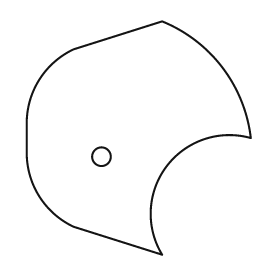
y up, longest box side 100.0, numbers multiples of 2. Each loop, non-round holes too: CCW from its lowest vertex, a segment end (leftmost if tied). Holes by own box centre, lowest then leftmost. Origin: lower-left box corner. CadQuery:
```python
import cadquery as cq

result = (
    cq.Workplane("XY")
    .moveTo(58.0, 0.0)
    .threePointArc((60.0, 38.0), (96.0, 50.0))
    .threePointArc((84.0, 80.0), (58.0, 100.0))
    .lineTo(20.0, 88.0)
    .threePointArc((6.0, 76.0), (0.0, 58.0))
    .lineTo(0.0, 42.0)
    .threePointArc((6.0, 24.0), (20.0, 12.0))
    .close()
    .moveTo(32.0, 42.0)
    .circle(4.0)
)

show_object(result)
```